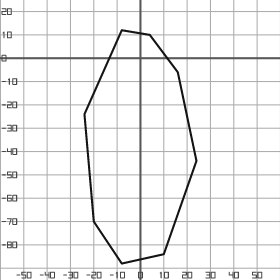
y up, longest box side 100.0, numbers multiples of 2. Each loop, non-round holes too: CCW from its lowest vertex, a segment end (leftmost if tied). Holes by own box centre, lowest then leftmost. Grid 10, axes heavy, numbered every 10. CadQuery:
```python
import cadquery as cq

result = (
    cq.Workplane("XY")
    .moveTo(-8.0, -88.0)
    .lineTo(10.0, -84.0)
    .lineTo(24.0, -44.0)
    .lineTo(16.0, -6.0)
    .lineTo(4.0, 10.0)
    .lineTo(-8.0, 12.0)
    .lineTo(-24.0, -24.0)
    .lineTo(-20.0, -70.0)
    .close()
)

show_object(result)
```